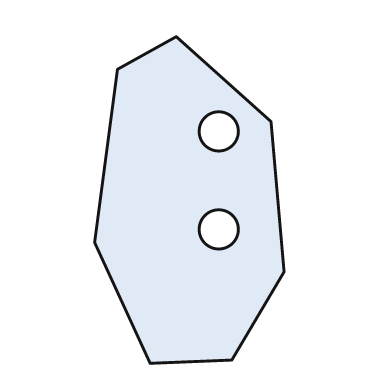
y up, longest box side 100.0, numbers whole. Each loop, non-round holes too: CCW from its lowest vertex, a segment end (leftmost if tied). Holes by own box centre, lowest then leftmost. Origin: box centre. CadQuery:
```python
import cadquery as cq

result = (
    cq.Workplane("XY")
    .moveTo(-12.0, -50.0)
    .lineTo(13.0, -49.0)
    .lineTo(29.0, -22.0)
    .lineTo(25.0, 24.0)
    .lineTo(-4.0, 50.0)
    .lineTo(-22.0, 40.0)
    .lineTo(-29.0, -13.0)
    .close()
    .moveTo(9.0, -9.0)
    .circle(6.0)
    .moveTo(9.0, 21.0)
    .circle(6.0)
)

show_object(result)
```